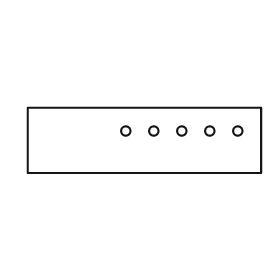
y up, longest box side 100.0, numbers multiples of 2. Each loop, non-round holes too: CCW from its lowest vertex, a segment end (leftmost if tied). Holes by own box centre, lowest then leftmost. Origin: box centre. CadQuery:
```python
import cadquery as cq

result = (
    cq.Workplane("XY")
    .moveTo(-50.0, -14.0)
    .lineTo(50.0, -14.0)
    .lineTo(50.0, 14.0)
    .lineTo(-50.0, 14.0)
    .close()
    .moveTo(-8.0, 4.0)
    .circle(2.0)
    .moveTo(4.0, 4.0)
    .circle(2.0)
    .moveTo(16.0, 4.0)
    .circle(2.0)
    .moveTo(28.0, 4.0)
    .circle(2.0)
    .moveTo(40.0, 4.0)
    .circle(2.0)
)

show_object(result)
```